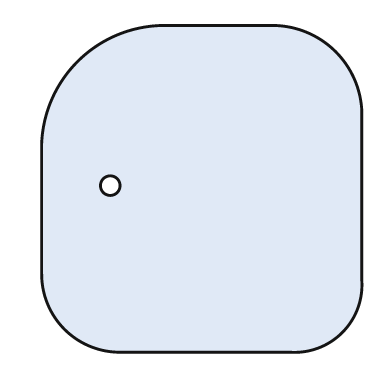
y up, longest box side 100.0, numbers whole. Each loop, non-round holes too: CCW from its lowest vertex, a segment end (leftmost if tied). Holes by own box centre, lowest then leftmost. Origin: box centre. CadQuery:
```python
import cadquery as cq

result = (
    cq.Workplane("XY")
    .moveTo(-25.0, -50.0)
    .lineTo(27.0, -50.0)
    .threePointArc((43.0, -44.0), (49.0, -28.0))
    .lineTo(49.0, 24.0)
    .threePointArc((41.0, 42.0), (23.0, 50.0))
    .lineTo(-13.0, 50.0)
    .threePointArc((-38.0, 39.0), (-49.0, 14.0))
    .lineTo(-49.0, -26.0)
    .threePointArc((-42.0, -43.0), (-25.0, -50.0))
    .close()
    .moveTo(-28.0, 1.0)
    .circle(3.0)
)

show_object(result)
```